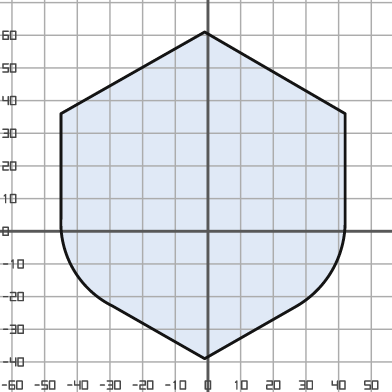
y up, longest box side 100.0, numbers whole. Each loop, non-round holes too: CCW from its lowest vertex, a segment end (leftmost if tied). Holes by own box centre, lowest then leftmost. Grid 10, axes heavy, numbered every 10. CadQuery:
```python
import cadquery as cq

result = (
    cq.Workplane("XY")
    .moveTo(-1.0, -39.0)
    .lineTo(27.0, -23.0)
    .threePointArc((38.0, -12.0), (42.0, 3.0))
    .lineTo(42.0, 36.0)
    .lineTo(-1.0, 61.0)
    .lineTo(-45.0, 36.0)
    .lineTo(-45.0, 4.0)
    .threePointArc((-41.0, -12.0), (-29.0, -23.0))
    .close()
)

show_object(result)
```